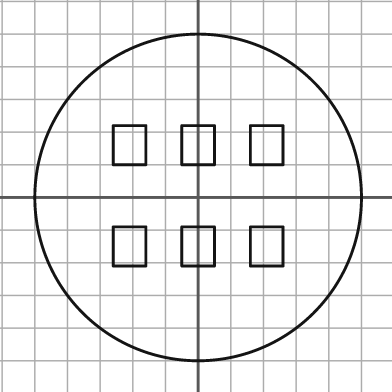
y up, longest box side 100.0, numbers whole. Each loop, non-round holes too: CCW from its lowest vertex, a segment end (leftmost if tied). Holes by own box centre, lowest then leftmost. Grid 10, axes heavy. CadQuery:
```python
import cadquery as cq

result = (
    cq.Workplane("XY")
    .moveTo(0.0, 0.0)
    .circle(50.0)
    .moveTo(-26.0, -21.0)
    .lineTo(-16.0, -21.0)
    .lineTo(-16.0, -9.0)
    .lineTo(-26.0, -9.0)
    .close()
    .moveTo(-5.0, -21.0)
    .lineTo(5.0, -21.0)
    .lineTo(5.0, -9.0)
    .lineTo(-5.0, -9.0)
    .close()
    .moveTo(16.0, -21.0)
    .lineTo(26.0, -21.0)
    .lineTo(26.0, -9.0)
    .lineTo(16.0, -9.0)
    .close()
    .moveTo(-26.0, 10.0)
    .lineTo(-16.0, 10.0)
    .lineTo(-16.0, 22.0)
    .lineTo(-26.0, 22.0)
    .close()
    .moveTo(-5.0, 10.0)
    .lineTo(5.0, 10.0)
    .lineTo(5.0, 22.0)
    .lineTo(-5.0, 22.0)
    .close()
    .moveTo(16.0, 10.0)
    .lineTo(26.0, 10.0)
    .lineTo(26.0, 22.0)
    .lineTo(16.0, 22.0)
    .close()
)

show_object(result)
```